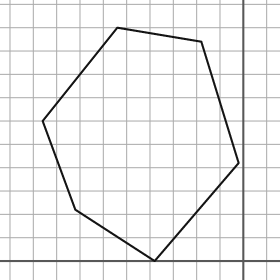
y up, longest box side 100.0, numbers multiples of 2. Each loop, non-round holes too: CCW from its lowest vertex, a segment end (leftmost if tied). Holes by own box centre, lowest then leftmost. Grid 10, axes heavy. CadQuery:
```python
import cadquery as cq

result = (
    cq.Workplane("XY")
    .moveTo(-38.0, 0.0)
    .lineTo(-2.0, 42.0)
    .lineTo(-18.0, 94.0)
    .lineTo(-54.0, 100.0)
    .lineTo(-86.0, 60.0)
    .lineTo(-72.0, 22.0)
    .close()
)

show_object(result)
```